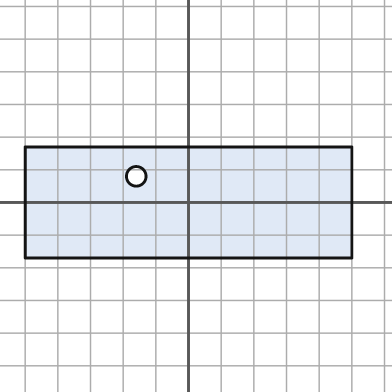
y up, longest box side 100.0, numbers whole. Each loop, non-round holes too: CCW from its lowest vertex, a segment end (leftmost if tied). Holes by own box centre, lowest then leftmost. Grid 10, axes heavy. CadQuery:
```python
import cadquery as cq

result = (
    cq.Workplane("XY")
    .moveTo(-50.0, -17.0)
    .lineTo(50.0, -17.0)
    .lineTo(50.0, 17.0)
    .lineTo(-50.0, 17.0)
    .close()
    .moveTo(-16.0, 8.0)
    .circle(3.0)
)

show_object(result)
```